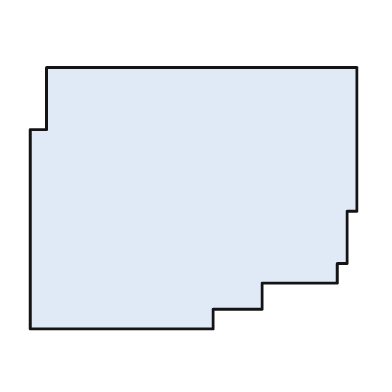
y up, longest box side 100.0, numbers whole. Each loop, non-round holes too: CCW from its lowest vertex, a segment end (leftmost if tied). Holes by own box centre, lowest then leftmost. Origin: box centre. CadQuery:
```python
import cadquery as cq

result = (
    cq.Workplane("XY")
    .moveTo(-50.0, -40.0)
    .lineTo(6.0, -40.0)
    .lineTo(6.0, -34.0)
    .lineTo(21.0, -34.0)
    .lineTo(21.0, -26.0)
    .lineTo(44.0, -26.0)
    .lineTo(44.0, -20.0)
    .lineTo(47.0, -20.0)
    .lineTo(47.0, -4.0)
    .lineTo(50.0, -4.0)
    .lineTo(50.0, 40.0)
    .lineTo(-45.0, 40.0)
    .lineTo(-45.0, 21.0)
    .lineTo(-50.0, 21.0)
    .close()
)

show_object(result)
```